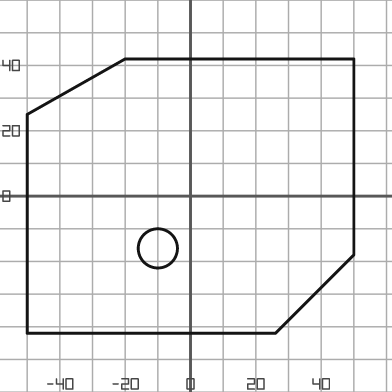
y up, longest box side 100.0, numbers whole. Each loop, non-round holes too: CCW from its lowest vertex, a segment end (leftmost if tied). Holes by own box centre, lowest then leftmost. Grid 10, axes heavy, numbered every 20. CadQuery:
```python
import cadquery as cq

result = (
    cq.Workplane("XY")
    .moveTo(-50.0, -42.0)
    .lineTo(26.0, -42.0)
    .lineTo(50.0, -18.0)
    .lineTo(50.0, 42.0)
    .lineTo(-20.0, 42.0)
    .lineTo(-50.0, 25.0)
    .close()
    .moveTo(-10.0, -16.0)
    .circle(6.0)
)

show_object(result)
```